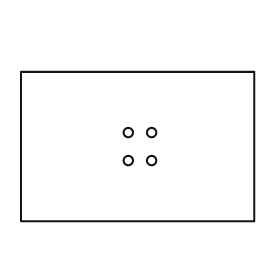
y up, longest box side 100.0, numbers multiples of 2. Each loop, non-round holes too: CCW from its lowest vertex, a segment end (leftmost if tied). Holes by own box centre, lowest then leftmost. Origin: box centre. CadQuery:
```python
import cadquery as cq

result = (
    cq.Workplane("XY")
    .moveTo(-50.0, -32.0)
    .lineTo(50.0, -32.0)
    .lineTo(50.0, 32.0)
    .lineTo(-50.0, 32.0)
    .close()
    .moveTo(-4.0, -6.0)
    .circle(2.0)
    .moveTo(6.0, -6.0)
    .circle(2.0)
    .moveTo(-4.0, 6.0)
    .circle(2.0)
    .moveTo(6.0, 6.0)
    .circle(2.0)
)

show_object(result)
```